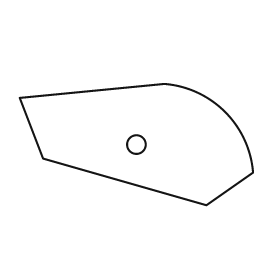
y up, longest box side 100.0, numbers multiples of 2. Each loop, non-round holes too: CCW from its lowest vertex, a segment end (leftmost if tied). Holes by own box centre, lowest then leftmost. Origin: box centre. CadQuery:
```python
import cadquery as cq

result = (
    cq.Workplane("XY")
    .moveTo(30.0, -26.0)
    .lineTo(50.0, -12.0)
    .threePointArc((38.0, 14.0), (12.0, 26.0))
    .lineTo(-50.0, 20.0)
    .lineTo(-40.0, -6.0)
    .close()
    .moveTo(0.0, 0.0)
    .circle(4.0)
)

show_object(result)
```